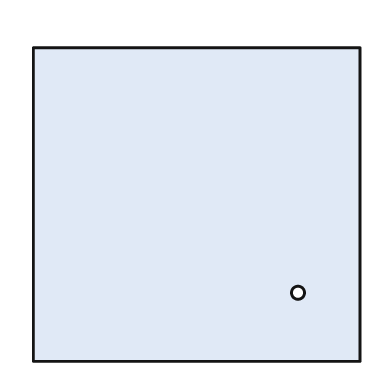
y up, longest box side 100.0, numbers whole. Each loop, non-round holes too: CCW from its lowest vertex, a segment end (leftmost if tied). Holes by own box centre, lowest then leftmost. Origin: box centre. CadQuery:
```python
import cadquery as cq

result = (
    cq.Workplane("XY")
    .moveTo(-50.0, -48.0)
    .lineTo(50.0, -48.0)
    .lineTo(50.0, 48.0)
    .lineTo(-50.0, 48.0)
    .close()
    .moveTo(31.0, -27.0)
    .circle(2.0)
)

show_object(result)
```